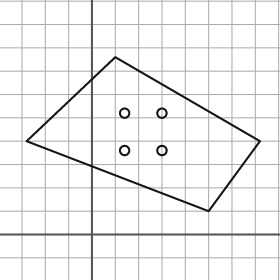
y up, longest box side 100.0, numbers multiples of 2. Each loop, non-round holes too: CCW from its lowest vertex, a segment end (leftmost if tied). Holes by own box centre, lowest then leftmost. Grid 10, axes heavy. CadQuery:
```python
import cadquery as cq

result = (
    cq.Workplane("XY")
    .moveTo(50.0, 10.0)
    .lineTo(72.0, 40.0)
    .lineTo(10.0, 76.0)
    .lineTo(-28.0, 40.0)
    .close()
    .moveTo(14.0, 36.0)
    .circle(2.0)
    .moveTo(30.0, 36.0)
    .circle(2.0)
    .moveTo(14.0, 52.0)
    .circle(2.0)
    .moveTo(30.0, 52.0)
    .circle(2.0)
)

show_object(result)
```